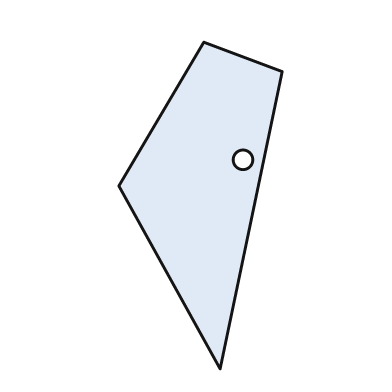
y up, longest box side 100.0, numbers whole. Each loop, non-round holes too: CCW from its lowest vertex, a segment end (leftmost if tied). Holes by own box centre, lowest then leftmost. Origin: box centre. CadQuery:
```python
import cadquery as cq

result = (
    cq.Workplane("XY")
    .moveTo(6.0, -50.0)
    .lineTo(25.0, 41.0)
    .lineTo(1.0, 50.0)
    .lineTo(-25.0, 6.0)
    .close()
    .moveTo(13.0, 14.0)
    .circle(3.0)
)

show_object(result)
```